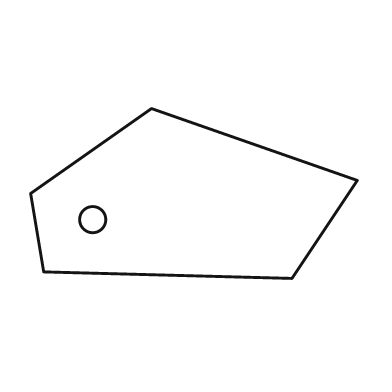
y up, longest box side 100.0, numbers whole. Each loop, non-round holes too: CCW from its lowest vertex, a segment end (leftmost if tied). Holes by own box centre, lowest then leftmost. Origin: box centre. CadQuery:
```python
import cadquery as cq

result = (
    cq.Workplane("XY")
    .moveTo(30.0, -26.0)
    .lineTo(50.0, 4.0)
    .lineTo(-13.0, 26.0)
    .lineTo(-50.0, 0.0)
    .lineTo(-46.0, -24.0)
    .close()
    .moveTo(-31.0, -8.0)
    .circle(4.0)
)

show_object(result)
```